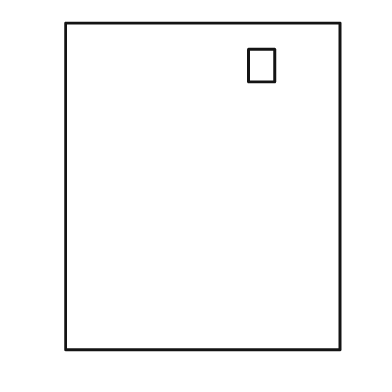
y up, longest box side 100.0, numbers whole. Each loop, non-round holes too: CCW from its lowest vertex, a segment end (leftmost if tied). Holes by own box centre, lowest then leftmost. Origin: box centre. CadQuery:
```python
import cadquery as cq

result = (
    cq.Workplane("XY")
    .moveTo(-42.0, -50.0)
    .lineTo(42.0, -50.0)
    .lineTo(42.0, 50.0)
    .lineTo(-42.0, 50.0)
    .close()
    .moveTo(14.0, 32.0)
    .lineTo(22.0, 32.0)
    .lineTo(22.0, 42.0)
    .lineTo(14.0, 42.0)
    .close()
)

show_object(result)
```